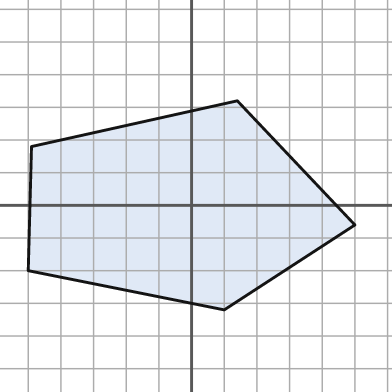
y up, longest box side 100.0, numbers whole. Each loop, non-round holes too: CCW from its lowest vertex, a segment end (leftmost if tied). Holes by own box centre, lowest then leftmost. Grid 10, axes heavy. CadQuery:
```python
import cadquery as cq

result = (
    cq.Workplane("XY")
    .moveTo(10.0, -32.0)
    .lineTo(50.0, -6.0)
    .lineTo(14.0, 32.0)
    .lineTo(-49.0, 18.0)
    .lineTo(-50.0, -20.0)
    .close()
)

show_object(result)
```